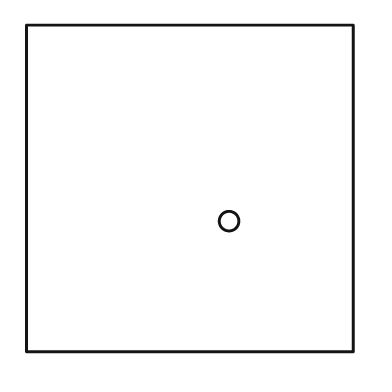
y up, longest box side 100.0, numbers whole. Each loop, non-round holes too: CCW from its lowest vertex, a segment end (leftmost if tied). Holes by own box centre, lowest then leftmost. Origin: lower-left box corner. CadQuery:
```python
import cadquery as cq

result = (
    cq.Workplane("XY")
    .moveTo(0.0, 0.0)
    .lineTo(100.0, 0.0)
    .lineTo(100.0, 100.0)
    .lineTo(0.0, 100.0)
    .close()
    .moveTo(62.0, 40.0)
    .circle(3.0)
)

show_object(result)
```